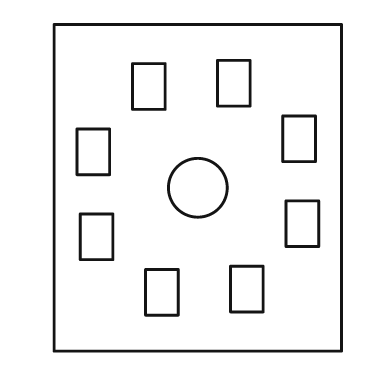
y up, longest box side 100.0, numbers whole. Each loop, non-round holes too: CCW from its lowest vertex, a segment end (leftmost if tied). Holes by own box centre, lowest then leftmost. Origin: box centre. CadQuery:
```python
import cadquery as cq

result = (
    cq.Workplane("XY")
    .moveTo(-44.0, -50.0)
    .lineTo(44.0, -50.0)
    .lineTo(44.0, 50.0)
    .lineTo(-44.0, 50.0)
    .close()
    .moveTo(-16.0, -39.0)
    .lineTo(-6.0, -39.0)
    .lineTo(-6.0, -25.0)
    .lineTo(-16.0, -25.0)
    .close()
    .moveTo(10.0, -38.0)
    .lineTo(20.0, -38.0)
    .lineTo(20.0, -24.0)
    .lineTo(10.0, -24.0)
    .close()
    .moveTo(-36.0, -22.0)
    .lineTo(-26.0, -22.0)
    .lineTo(-26.0, -8.0)
    .lineTo(-36.0, -8.0)
    .close()
    .moveTo(27.0, -18.0)
    .lineTo(37.0, -18.0)
    .lineTo(37.0, -4.0)
    .lineTo(27.0, -4.0)
    .close()
    .moveTo(0.0, 0.0)
    .circle(9.0)
    .moveTo(-37.0, 4.0)
    .lineTo(-27.0, 4.0)
    .lineTo(-27.0, 18.0)
    .lineTo(-37.0, 18.0)
    .close()
    .moveTo(26.0, 8.0)
    .lineTo(36.0, 8.0)
    .lineTo(36.0, 22.0)
    .lineTo(26.0, 22.0)
    .close()
    .moveTo(-20.0, 24.0)
    .lineTo(-10.0, 24.0)
    .lineTo(-10.0, 38.0)
    .lineTo(-20.0, 38.0)
    .close()
    .moveTo(6.0, 25.0)
    .lineTo(16.0, 25.0)
    .lineTo(16.0, 39.0)
    .lineTo(6.0, 39.0)
    .close()
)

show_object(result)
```